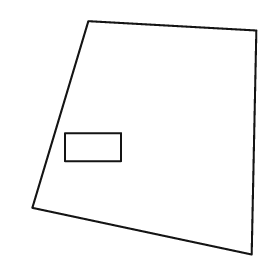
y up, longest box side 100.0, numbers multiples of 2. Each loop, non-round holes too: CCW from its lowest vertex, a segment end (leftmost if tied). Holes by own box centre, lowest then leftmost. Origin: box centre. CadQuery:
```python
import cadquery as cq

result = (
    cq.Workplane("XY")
    .moveTo(46.0, -50.0)
    .lineTo(48.0, 46.0)
    .lineTo(-24.0, 50.0)
    .lineTo(-48.0, -30.0)
    .close()
    .moveTo(-34.0, -10.0)
    .lineTo(-10.0, -10.0)
    .lineTo(-10.0, 2.0)
    .lineTo(-34.0, 2.0)
    .close()
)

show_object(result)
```